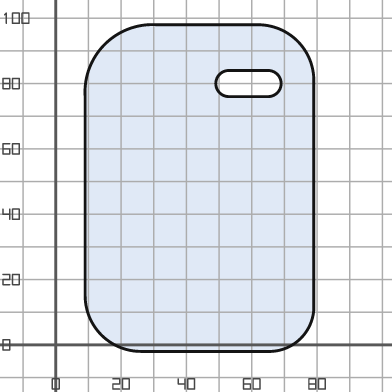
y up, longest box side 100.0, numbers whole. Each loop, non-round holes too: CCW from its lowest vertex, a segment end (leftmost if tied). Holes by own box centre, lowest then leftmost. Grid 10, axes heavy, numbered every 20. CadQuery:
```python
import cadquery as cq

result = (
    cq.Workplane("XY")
    .moveTo(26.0, -2.0)
    .lineTo(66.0, -2.0)
    .threePointArc((75.0, 2.0), (79.0, 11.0))
    .lineTo(79.0, 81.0)
    .threePointArc((74.0, 93.0), (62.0, 98.0))
    .lineTo(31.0, 98.0)
    .threePointArc((15.0, 92.0), (9.0, 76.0))
    .lineTo(9.0, 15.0)
    .threePointArc((14.0, 3.0), (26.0, -2.0))
    .close()
    .moveTo(53.0, 76.0)
    .lineTo(65.0, 76.0)
    .threePointArc((69.0, 80.0), (65.0, 84.0))
    .lineTo(53.0, 84.0)
    .threePointArc((49.0, 80.0), (53.0, 76.0))
    .close()
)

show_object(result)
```